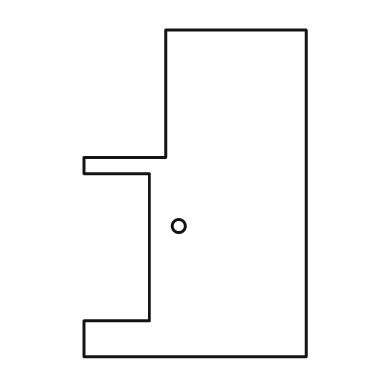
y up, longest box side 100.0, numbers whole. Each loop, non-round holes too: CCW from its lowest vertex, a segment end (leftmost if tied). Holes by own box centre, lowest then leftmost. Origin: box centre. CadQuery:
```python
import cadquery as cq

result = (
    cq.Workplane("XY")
    .moveTo(-34.0, -50.0)
    .lineTo(34.0, -50.0)
    .lineTo(34.0, 50.0)
    .lineTo(-9.0, 50.0)
    .lineTo(-9.0, 11.0)
    .lineTo(-34.0, 11.0)
    .lineTo(-34.0, 6.0)
    .lineTo(-14.0, 6.0)
    .lineTo(-14.0, -39.0)
    .lineTo(-34.0, -39.0)
    .close()
    .moveTo(-5.0, -10.0)
    .circle(2.0)
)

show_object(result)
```